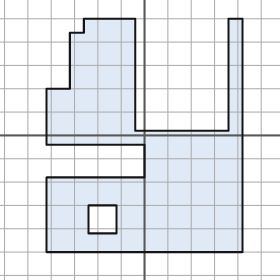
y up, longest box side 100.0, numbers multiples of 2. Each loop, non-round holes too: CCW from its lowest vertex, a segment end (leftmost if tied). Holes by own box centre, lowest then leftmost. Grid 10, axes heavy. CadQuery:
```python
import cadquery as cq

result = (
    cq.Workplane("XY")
    .moveTo(-42.0, -50.0)
    .lineTo(42.0, -50.0)
    .lineTo(42.0, 50.0)
    .lineTo(36.0, 50.0)
    .lineTo(36.0, 2.0)
    .lineTo(-4.0, 2.0)
    .lineTo(-4.0, 50.0)
    .lineTo(-26.0, 50.0)
    .lineTo(-26.0, 44.0)
    .lineTo(-32.0, 44.0)
    .lineTo(-32.0, 20.0)
    .lineTo(-42.0, 20.0)
    .lineTo(-42.0, -4.0)
    .lineTo(0.0, -4.0)
    .lineTo(0.0, -18.0)
    .lineTo(-42.0, -18.0)
    .close()
    .moveTo(-24.0, -42.0)
    .lineTo(-12.0, -42.0)
    .lineTo(-12.0, -30.0)
    .lineTo(-24.0, -30.0)
    .close()
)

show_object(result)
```